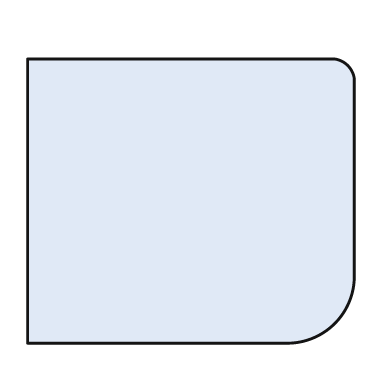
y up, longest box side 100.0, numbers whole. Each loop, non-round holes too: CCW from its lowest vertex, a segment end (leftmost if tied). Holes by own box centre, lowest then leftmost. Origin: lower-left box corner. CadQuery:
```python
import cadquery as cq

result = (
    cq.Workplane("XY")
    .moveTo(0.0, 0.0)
    .lineTo(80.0, 0.0)
    .threePointArc((94.0, 6.0), (100.0, 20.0))
    .lineTo(100.0, 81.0)
    .threePointArc((98.0, 85.0), (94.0, 87.0))
    .lineTo(0.0, 87.0)
    .close()
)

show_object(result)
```